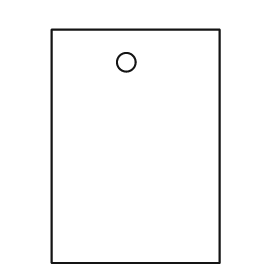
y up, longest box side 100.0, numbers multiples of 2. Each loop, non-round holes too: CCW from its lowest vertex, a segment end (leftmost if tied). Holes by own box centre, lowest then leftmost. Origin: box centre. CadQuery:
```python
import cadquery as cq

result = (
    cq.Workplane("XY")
    .moveTo(-36.0, -50.0)
    .lineTo(36.0, -50.0)
    .lineTo(36.0, 50.0)
    .lineTo(-36.0, 50.0)
    .close()
    .moveTo(-4.0, 36.0)
    .circle(4.0)
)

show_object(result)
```